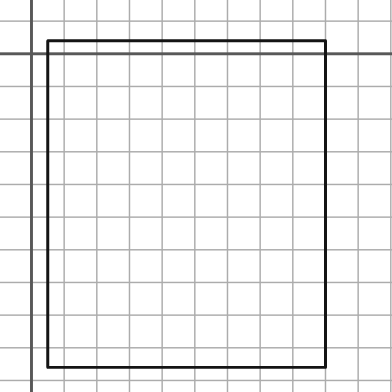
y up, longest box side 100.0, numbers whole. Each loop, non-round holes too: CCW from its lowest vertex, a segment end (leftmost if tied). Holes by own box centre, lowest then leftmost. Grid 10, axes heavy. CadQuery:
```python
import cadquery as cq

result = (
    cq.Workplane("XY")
    .moveTo(5.0, -96.0)
    .lineTo(90.0, -96.0)
    .lineTo(90.0, 4.0)
    .lineTo(5.0, 4.0)
    .close()
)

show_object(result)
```